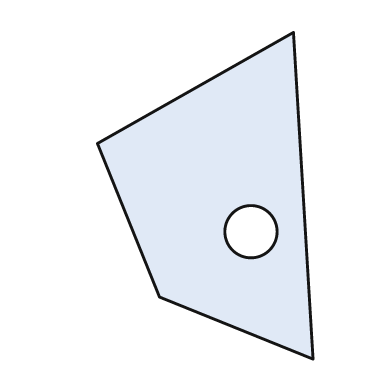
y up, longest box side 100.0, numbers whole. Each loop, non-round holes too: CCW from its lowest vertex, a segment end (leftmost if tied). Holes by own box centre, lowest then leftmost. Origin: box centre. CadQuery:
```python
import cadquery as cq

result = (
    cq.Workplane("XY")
    .moveTo(33.0, -50.0)
    .lineTo(27.0, 50.0)
    .lineTo(-33.0, 16.0)
    .lineTo(-14.0, -31.0)
    .close()
    .moveTo(14.0, -11.0)
    .circle(8.0)
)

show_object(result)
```